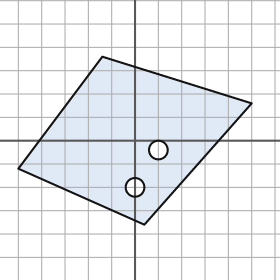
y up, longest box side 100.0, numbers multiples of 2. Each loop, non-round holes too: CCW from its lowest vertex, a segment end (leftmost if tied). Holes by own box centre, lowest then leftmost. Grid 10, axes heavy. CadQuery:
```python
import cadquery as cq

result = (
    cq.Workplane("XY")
    .moveTo(4.0, -36.0)
    .lineTo(50.0, 16.0)
    .lineTo(-14.0, 36.0)
    .lineTo(-50.0, -12.0)
    .close()
    .moveTo(0.0, -20.0)
    .circle(4.0)
    .moveTo(10.0, -4.0)
    .circle(4.0)
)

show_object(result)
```